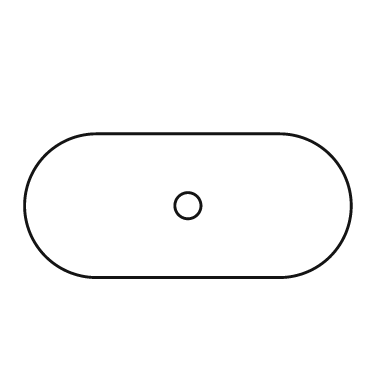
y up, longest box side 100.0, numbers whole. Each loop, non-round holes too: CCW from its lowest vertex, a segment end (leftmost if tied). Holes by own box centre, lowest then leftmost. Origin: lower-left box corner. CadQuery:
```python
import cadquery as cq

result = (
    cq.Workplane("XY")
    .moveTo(22.0, 0.0)
    .lineTo(78.0, 0.0)
    .threePointArc((100.0, 22.0), (78.0, 44.0))
    .lineTo(22.0, 44.0)
    .threePointArc((0.0, 22.0), (22.0, 0.0))
    .close()
    .moveTo(50.0, 22.0)
    .circle(4.0)
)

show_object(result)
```